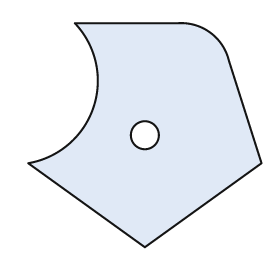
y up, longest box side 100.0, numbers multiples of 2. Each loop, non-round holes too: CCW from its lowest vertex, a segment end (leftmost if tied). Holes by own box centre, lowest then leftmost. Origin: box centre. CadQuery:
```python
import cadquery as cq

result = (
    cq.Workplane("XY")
    .moveTo(0.0, -48.0)
    .lineTo(50.0, -12.0)
    .lineTo(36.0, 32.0)
    .threePointArc((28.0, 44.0), (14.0, 48.0))
    .lineTo(-30.0, 48.0)
    .threePointArc((-22.0, 12.0), (-50.0, -12.0))
    .close()
    .moveTo(0.0, 0.0)
    .circle(6.0)
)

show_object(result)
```